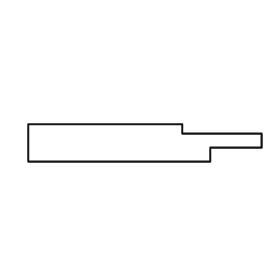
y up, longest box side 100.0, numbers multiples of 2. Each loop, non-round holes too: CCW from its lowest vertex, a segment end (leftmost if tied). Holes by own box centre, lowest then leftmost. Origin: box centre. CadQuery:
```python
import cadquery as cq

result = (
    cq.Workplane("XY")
    .moveTo(-50.0, -8.0)
    .lineTo(28.0, -8.0)
    .lineTo(28.0, -2.0)
    .lineTo(50.0, -2.0)
    .lineTo(50.0, 4.0)
    .lineTo(16.0, 4.0)
    .lineTo(16.0, 8.0)
    .lineTo(-50.0, 8.0)
    .close()
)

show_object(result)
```